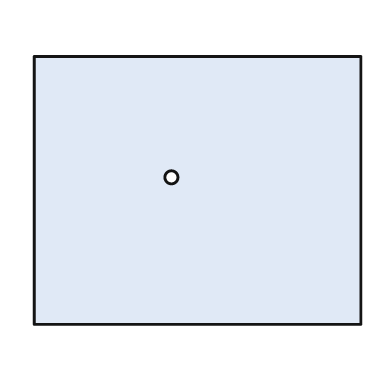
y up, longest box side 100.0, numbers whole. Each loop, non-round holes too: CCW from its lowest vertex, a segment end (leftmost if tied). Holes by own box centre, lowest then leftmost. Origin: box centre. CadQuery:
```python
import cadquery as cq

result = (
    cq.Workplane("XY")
    .moveTo(-50.0, -41.0)
    .lineTo(50.0, -41.0)
    .lineTo(50.0, 41.0)
    .lineTo(-50.0, 41.0)
    .close()
    .moveTo(-8.0, 4.0)
    .circle(2.0)
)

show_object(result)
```